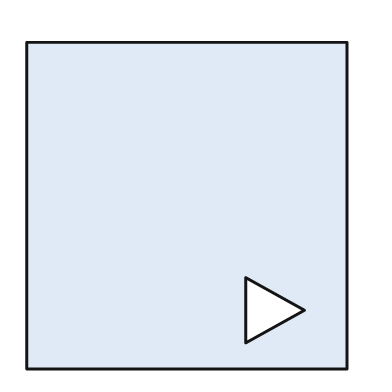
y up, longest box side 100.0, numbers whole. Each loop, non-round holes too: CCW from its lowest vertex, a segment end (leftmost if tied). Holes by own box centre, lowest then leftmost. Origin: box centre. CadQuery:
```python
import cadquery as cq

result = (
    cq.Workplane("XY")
    .moveTo(-49.0, -50.0)
    .lineTo(49.0, -50.0)
    .lineTo(49.0, 50.0)
    .lineTo(-49.0, 50.0)
    .close()
    .moveTo(18.0, -42.0)
    .lineTo(36.0, -32.0)
    .lineTo(18.0, -22.0)
    .close()
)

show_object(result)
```